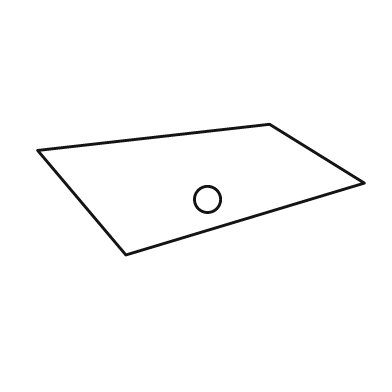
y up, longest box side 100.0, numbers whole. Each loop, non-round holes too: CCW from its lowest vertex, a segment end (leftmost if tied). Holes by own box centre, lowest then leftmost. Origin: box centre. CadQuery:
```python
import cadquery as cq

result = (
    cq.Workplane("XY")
    .moveTo(-23.0, -20.0)
    .lineTo(50.0, 2.0)
    .lineTo(21.0, 20.0)
    .lineTo(-50.0, 12.0)
    .close()
    .moveTo(2.0, -3.0)
    .circle(4.0)
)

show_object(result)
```